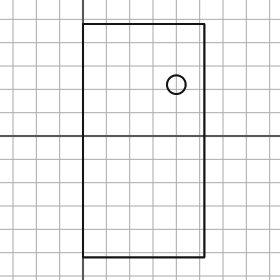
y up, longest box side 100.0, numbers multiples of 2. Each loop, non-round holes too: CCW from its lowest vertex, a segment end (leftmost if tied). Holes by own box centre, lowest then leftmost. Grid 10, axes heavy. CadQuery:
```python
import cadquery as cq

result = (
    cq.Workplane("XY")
    .moveTo(0.0, -52.0)
    .lineTo(52.0, -52.0)
    .lineTo(52.0, 48.0)
    .lineTo(0.0, 48.0)
    .close()
    .moveTo(40.0, 22.0)
    .circle(4.0)
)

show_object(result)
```